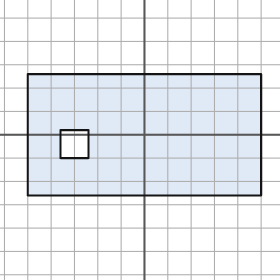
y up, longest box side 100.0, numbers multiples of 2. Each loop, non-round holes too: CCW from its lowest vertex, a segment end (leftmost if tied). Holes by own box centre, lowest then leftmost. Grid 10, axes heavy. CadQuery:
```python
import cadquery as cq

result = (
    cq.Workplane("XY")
    .moveTo(-50.0, -26.0)
    .lineTo(50.0, -26.0)
    .lineTo(50.0, 26.0)
    .lineTo(-50.0, 26.0)
    .close()
    .moveTo(-36.0, -10.0)
    .lineTo(-24.0, -10.0)
    .lineTo(-24.0, 2.0)
    .lineTo(-36.0, 2.0)
    .close()
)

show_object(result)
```